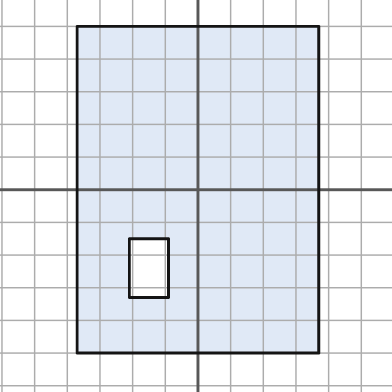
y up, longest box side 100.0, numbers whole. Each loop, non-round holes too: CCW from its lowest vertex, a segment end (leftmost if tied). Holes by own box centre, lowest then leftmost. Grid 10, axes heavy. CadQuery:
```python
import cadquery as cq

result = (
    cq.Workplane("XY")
    .moveTo(-37.0, -50.0)
    .lineTo(37.0, -50.0)
    .lineTo(37.0, 50.0)
    .lineTo(-37.0, 50.0)
    .close()
    .moveTo(-21.0, -33.0)
    .lineTo(-9.0, -33.0)
    .lineTo(-9.0, -15.0)
    .lineTo(-21.0, -15.0)
    .close()
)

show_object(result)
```